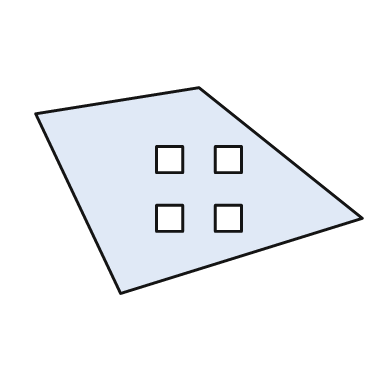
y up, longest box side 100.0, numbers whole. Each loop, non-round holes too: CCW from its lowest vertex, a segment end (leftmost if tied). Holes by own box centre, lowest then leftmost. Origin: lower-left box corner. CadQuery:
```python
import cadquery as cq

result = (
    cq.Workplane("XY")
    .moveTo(26.0, 0.0)
    .lineTo(100.0, 23.0)
    .lineTo(50.0, 63.0)
    .lineTo(0.0, 55.0)
    .close()
    .moveTo(37.0, 19.0)
    .lineTo(45.0, 19.0)
    .lineTo(45.0, 27.0)
    .lineTo(37.0, 27.0)
    .close()
    .moveTo(55.0, 19.0)
    .lineTo(63.0, 19.0)
    .lineTo(63.0, 27.0)
    .lineTo(55.0, 27.0)
    .close()
    .moveTo(37.0, 37.0)
    .lineTo(45.0, 37.0)
    .lineTo(45.0, 45.0)
    .lineTo(37.0, 45.0)
    .close()
    .moveTo(55.0, 37.0)
    .lineTo(63.0, 37.0)
    .lineTo(63.0, 45.0)
    .lineTo(55.0, 45.0)
    .close()
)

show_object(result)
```